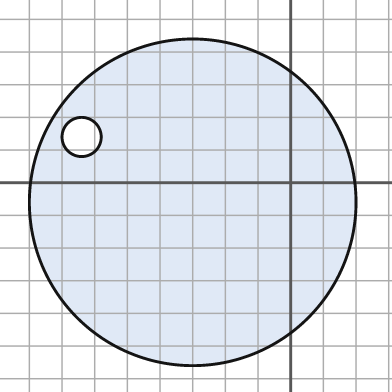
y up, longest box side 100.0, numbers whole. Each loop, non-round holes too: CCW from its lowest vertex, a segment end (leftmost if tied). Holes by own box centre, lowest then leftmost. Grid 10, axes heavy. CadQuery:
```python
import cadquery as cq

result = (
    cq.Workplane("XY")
    .moveTo(-30.0, -6.0)
    .circle(50.0)
    .moveTo(-64.0, 14.0)
    .circle(6.0)
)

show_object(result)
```